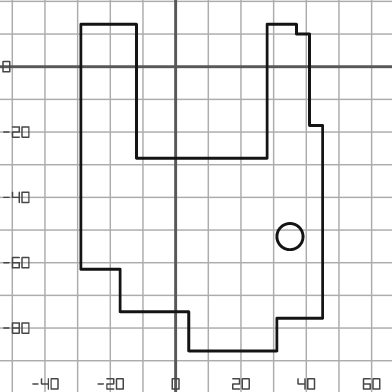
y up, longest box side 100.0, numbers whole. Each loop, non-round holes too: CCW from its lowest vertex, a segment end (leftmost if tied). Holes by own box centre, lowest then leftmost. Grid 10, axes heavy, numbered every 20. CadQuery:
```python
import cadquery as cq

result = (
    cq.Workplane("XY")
    .moveTo(4.0, -87.0)
    .lineTo(31.0, -87.0)
    .lineTo(31.0, -77.0)
    .lineTo(45.0, -77.0)
    .lineTo(45.0, -18.0)
    .lineTo(41.0, -18.0)
    .lineTo(41.0, 10.0)
    .lineTo(37.0, 10.0)
    .lineTo(37.0, 13.0)
    .lineTo(28.0, 13.0)
    .lineTo(28.0, -28.0)
    .lineTo(-12.0, -28.0)
    .lineTo(-12.0, 13.0)
    .lineTo(-29.0, 13.0)
    .lineTo(-29.0, -62.0)
    .lineTo(-17.0, -62.0)
    .lineTo(-17.0, -75.0)
    .lineTo(4.0, -75.0)
    .close()
    .moveTo(35.0, -52.0)
    .circle(4.0)
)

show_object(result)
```